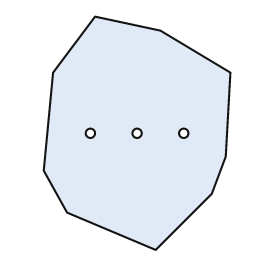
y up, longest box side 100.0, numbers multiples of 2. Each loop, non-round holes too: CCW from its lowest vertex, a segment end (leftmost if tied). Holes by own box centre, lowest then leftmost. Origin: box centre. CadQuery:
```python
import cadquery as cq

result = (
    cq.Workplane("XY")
    .moveTo(8.0, -50.0)
    .lineTo(32.0, -26.0)
    .lineTo(38.0, -10.0)
    .lineTo(40.0, 26.0)
    .lineTo(10.0, 44.0)
    .lineTo(-18.0, 50.0)
    .lineTo(-36.0, 26.0)
    .lineTo(-40.0, -16.0)
    .lineTo(-30.0, -34.0)
    .close()
    .moveTo(-20.0, 0.0)
    .circle(2.0)
    .moveTo(0.0, 0.0)
    .circle(2.0)
    .moveTo(20.0, 0.0)
    .circle(2.0)
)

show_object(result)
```